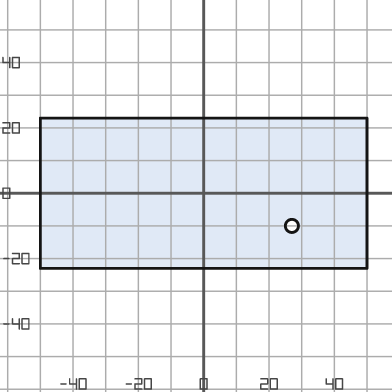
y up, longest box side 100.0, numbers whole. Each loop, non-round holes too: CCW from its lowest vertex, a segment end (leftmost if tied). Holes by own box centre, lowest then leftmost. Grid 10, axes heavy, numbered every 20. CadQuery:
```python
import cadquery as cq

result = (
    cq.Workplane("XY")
    .moveTo(-50.0, -23.0)
    .lineTo(50.0, -23.0)
    .lineTo(50.0, 23.0)
    .lineTo(-50.0, 23.0)
    .close()
    .moveTo(27.0, -10.0)
    .circle(2.0)
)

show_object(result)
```